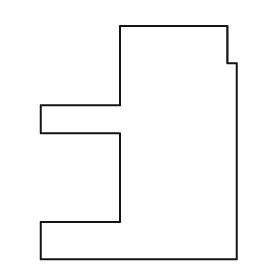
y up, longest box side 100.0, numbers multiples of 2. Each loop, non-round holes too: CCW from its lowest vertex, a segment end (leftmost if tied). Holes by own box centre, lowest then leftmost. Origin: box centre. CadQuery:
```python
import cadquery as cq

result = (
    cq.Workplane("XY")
    .moveTo(-42.0, -50.0)
    .lineTo(42.0, -50.0)
    .lineTo(42.0, 34.0)
    .lineTo(38.0, 34.0)
    .lineTo(38.0, 50.0)
    .lineTo(-8.0, 50.0)
    .lineTo(-8.0, 16.0)
    .lineTo(-42.0, 16.0)
    .lineTo(-42.0, 4.0)
    .lineTo(-8.0, 4.0)
    .lineTo(-8.0, -34.0)
    .lineTo(-42.0, -34.0)
    .close()
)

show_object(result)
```